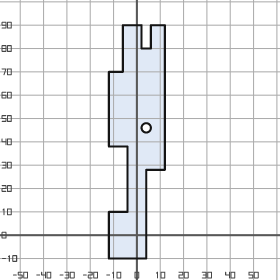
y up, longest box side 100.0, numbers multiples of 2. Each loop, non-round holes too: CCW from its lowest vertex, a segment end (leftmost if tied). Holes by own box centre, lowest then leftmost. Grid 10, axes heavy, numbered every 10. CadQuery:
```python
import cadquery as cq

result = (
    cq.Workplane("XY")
    .moveTo(-12.0, -10.0)
    .lineTo(4.0, -10.0)
    .lineTo(4.0, 28.0)
    .lineTo(12.0, 28.0)
    .lineTo(12.0, 90.0)
    .lineTo(6.0, 90.0)
    .lineTo(6.0, 80.0)
    .lineTo(2.0, 80.0)
    .lineTo(2.0, 90.0)
    .lineTo(-6.0, 90.0)
    .lineTo(-6.0, 70.0)
    .lineTo(-12.0, 70.0)
    .lineTo(-12.0, 38.0)
    .lineTo(-4.0, 38.0)
    .lineTo(-4.0, 10.0)
    .lineTo(-12.0, 10.0)
    .close()
    .moveTo(4.0, 46.0)
    .circle(2.0)
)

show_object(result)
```